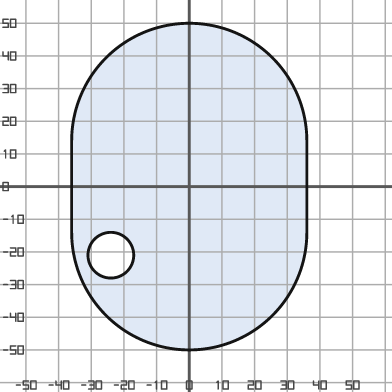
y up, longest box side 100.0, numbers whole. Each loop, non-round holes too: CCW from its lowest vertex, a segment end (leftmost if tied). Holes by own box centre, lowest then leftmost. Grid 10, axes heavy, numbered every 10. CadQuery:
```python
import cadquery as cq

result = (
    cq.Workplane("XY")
    .moveTo(-36.0, -14.0)
    .threePointArc((0.0, -50.0), (36.0, -14.0))
    .lineTo(36.0, 14.0)
    .threePointArc((0.0, 50.0), (-36.0, 14.0))
    .close()
    .moveTo(-24.0, -21.0)
    .circle(7.0)
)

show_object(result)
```